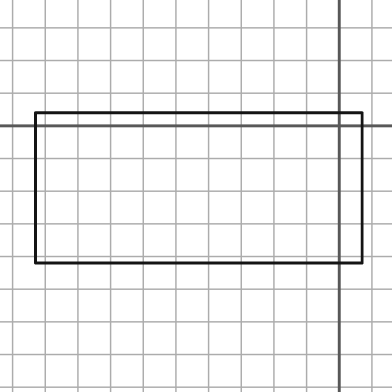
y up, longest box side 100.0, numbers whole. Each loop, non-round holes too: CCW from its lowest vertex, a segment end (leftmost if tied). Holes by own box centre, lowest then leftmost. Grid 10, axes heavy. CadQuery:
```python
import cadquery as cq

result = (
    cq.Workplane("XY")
    .moveTo(-93.0, -42.0)
    .lineTo(7.0, -42.0)
    .lineTo(7.0, 4.0)
    .lineTo(-93.0, 4.0)
    .close()
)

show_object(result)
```